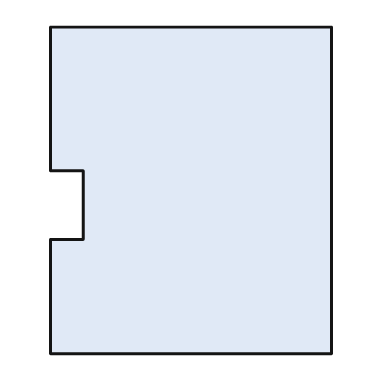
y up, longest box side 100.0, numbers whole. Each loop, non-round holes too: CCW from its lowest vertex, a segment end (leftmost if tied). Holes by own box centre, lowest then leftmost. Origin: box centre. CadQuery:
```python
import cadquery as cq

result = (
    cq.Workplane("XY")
    .moveTo(-43.0, -50.0)
    .lineTo(43.0, -50.0)
    .lineTo(43.0, 50.0)
    .lineTo(-43.0, 50.0)
    .lineTo(-43.0, 6.0)
    .lineTo(-33.0, 6.0)
    .lineTo(-33.0, -15.0)
    .lineTo(-43.0, -15.0)
    .close()
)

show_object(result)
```